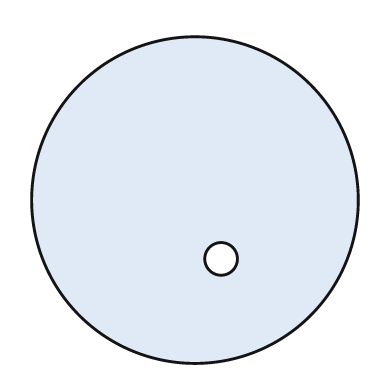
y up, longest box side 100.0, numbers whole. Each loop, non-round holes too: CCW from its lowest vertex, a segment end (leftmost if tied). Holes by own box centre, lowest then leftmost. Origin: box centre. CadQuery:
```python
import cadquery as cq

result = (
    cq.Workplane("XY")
    .moveTo(0.0, 0.0)
    .circle(50.0)
    .moveTo(8.0, -18.0)
    .circle(5.0)
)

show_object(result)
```